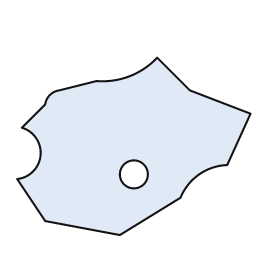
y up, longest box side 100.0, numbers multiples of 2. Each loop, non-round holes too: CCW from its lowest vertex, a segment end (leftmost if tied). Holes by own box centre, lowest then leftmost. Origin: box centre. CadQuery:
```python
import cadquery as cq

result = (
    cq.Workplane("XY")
    .moveTo(-6.0, -38.0)
    .lineTo(20.0, -22.0)
    .threePointArc((28.0, -12.0), (40.0, -8.0))
    .lineTo(50.0, 14.0)
    .lineTo(24.0, 24.0)
    .lineTo(10.0, 38.0)
    .threePointArc((-2.0, 30.0), (-16.0, 28.0))
    .lineTo(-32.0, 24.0)
    .threePointArc((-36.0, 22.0), (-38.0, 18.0))
    .lineTo(-48.0, 8.0)
    .threePointArc((-40.0, -4.0), (-50.0, -14.0))
    .lineTo(-38.0, -32.0)
    .close()
    .moveTo(0.0, -12.0)
    .circle(6.0)
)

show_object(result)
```